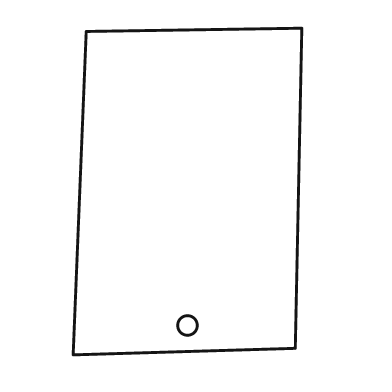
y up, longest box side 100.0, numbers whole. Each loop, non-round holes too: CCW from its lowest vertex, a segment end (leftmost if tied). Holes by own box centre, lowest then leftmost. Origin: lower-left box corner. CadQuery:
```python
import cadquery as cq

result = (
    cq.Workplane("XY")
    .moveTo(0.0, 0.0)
    .lineTo(68.0, 2.0)
    .lineTo(70.0, 100.0)
    .lineTo(4.0, 99.0)
    .close()
    .moveTo(35.0, 9.0)
    .circle(3.0)
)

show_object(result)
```